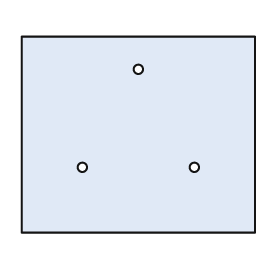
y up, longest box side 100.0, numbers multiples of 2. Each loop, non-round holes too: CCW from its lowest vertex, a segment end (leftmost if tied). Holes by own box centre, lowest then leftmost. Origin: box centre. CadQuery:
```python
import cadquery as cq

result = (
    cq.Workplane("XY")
    .moveTo(-50.0, -42.0)
    .lineTo(50.0, -42.0)
    .lineTo(50.0, 42.0)
    .lineTo(-50.0, 42.0)
    .close()
    .moveTo(-24.0, -14.0)
    .circle(2.0)
    .moveTo(24.0, -14.0)
    .circle(2.0)
    .moveTo(0.0, 28.0)
    .circle(2.0)
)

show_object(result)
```